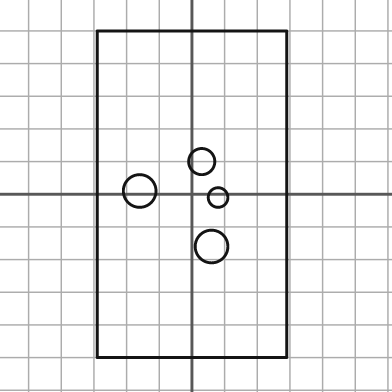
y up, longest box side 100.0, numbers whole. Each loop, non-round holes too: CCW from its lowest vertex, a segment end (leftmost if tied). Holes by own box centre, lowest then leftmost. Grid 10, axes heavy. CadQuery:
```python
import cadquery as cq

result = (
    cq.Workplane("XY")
    .moveTo(-29.0, -50.0)
    .lineTo(29.0, -50.0)
    .lineTo(29.0, 50.0)
    .lineTo(-29.0, 50.0)
    .close()
    .moveTo(6.0, -16.0)
    .circle(5.0)
    .moveTo(8.0, -1.0)
    .circle(3.0)
    .moveTo(-16.0, 1.0)
    .circle(5.0)
    .moveTo(3.0, 10.0)
    .circle(4.0)
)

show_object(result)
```